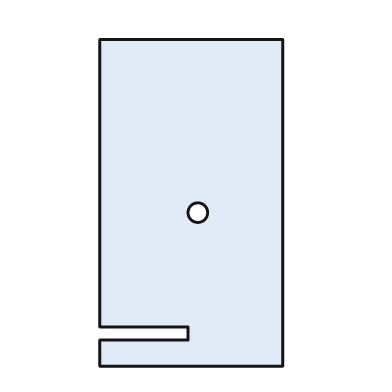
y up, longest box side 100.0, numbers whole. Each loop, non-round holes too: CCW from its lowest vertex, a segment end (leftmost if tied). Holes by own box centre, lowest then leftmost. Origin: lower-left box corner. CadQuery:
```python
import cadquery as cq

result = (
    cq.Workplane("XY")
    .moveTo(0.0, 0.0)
    .lineTo(56.0, 0.0)
    .lineTo(56.0, 100.0)
    .lineTo(0.0, 100.0)
    .lineTo(0.0, 12.0)
    .lineTo(27.0, 12.0)
    .lineTo(27.0, 8.0)
    .lineTo(0.0, 8.0)
    .close()
    .moveTo(30.0, 47.0)
    .circle(3.0)
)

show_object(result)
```